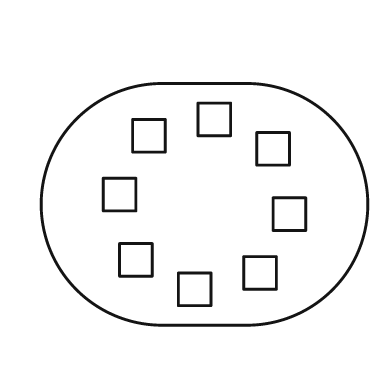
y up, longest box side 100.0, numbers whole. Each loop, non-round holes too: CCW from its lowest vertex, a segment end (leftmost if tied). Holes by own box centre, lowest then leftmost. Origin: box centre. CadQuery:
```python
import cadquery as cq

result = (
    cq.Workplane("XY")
    .moveTo(-13.0, -37.0)
    .lineTo(13.0, -37.0)
    .threePointArc((50.0, 0.0), (13.0, 37.0))
    .lineTo(-13.0, 37.0)
    .threePointArc((-50.0, 0.0), (-13.0, -37.0))
    .close()
    .moveTo(-8.0, -31.0)
    .lineTo(2.0, -31.0)
    .lineTo(2.0, -21.0)
    .lineTo(-8.0, -21.0)
    .close()
    .moveTo(12.0, -26.0)
    .lineTo(22.0, -26.0)
    .lineTo(22.0, -16.0)
    .lineTo(12.0, -16.0)
    .close()
    .moveTo(-26.0, -22.0)
    .lineTo(-16.0, -22.0)
    .lineTo(-16.0, -12.0)
    .lineTo(-26.0, -12.0)
    .close()
    .moveTo(21.0, -8.0)
    .lineTo(31.0, -8.0)
    .lineTo(31.0, 2.0)
    .lineTo(21.0, 2.0)
    .close()
    .moveTo(-31.0, -2.0)
    .lineTo(-21.0, -2.0)
    .lineTo(-21.0, 8.0)
    .lineTo(-31.0, 8.0)
    .close()
    .moveTo(16.0, 12.0)
    .lineTo(26.0, 12.0)
    .lineTo(26.0, 22.0)
    .lineTo(16.0, 22.0)
    .close()
    .moveTo(-22.0, 16.0)
    .lineTo(-12.0, 16.0)
    .lineTo(-12.0, 26.0)
    .lineTo(-22.0, 26.0)
    .close()
    .moveTo(-2.0, 21.0)
    .lineTo(8.0, 21.0)
    .lineTo(8.0, 31.0)
    .lineTo(-2.0, 31.0)
    .close()
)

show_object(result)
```